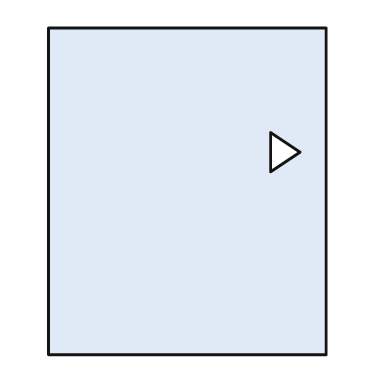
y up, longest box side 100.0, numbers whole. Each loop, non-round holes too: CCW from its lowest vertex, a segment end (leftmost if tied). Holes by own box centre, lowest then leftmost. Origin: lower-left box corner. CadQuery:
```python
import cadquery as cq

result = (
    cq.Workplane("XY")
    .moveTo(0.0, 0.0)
    .lineTo(85.0, 0.0)
    .lineTo(85.0, 100.0)
    .lineTo(0.0, 100.0)
    .close()
    .moveTo(68.0, 56.0)
    .lineTo(77.0, 62.0)
    .lineTo(68.0, 68.0)
    .close()
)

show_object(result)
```